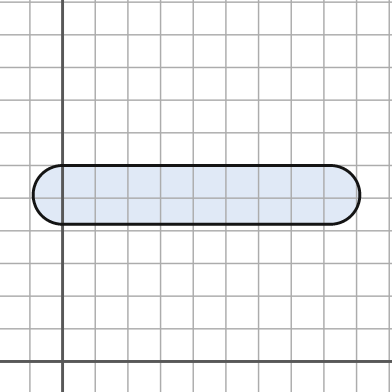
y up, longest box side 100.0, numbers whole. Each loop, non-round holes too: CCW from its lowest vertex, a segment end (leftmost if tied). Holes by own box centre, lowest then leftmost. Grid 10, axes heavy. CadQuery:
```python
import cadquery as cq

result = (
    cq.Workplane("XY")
    .moveTo(0.0, 42.0)
    .lineTo(82.0, 42.0)
    .threePointArc((91.0, 51.0), (82.0, 60.0))
    .lineTo(0.0, 60.0)
    .threePointArc((-9.0, 51.0), (0.0, 42.0))
    .close()
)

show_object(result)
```